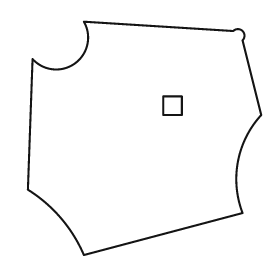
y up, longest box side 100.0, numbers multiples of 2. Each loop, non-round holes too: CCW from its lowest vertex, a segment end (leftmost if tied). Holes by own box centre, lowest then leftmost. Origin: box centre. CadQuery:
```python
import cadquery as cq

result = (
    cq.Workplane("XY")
    .moveTo(-26.0, -50.0)
    .lineTo(42.0, -32.0)
    .threePointArc((40.0, -10.0), (50.0, 10.0))
    .lineTo(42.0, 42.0)
    .threePointArc((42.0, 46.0), (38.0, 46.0))
    .lineTo(-26.0, 50.0)
    .threePointArc((-30.0, 32.0), (-48.0, 34.0))
    .lineTo(-50.0, -22.0)
    .threePointArc((-36.0, -34.0), (-26.0, -50.0))
    .close()
    .moveTo(8.0, 10.0)
    .lineTo(16.0, 10.0)
    .lineTo(16.0, 18.0)
    .lineTo(8.0, 18.0)
    .close()
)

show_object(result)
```